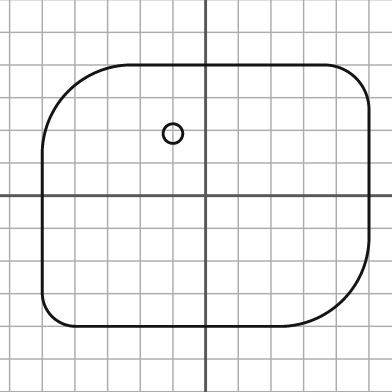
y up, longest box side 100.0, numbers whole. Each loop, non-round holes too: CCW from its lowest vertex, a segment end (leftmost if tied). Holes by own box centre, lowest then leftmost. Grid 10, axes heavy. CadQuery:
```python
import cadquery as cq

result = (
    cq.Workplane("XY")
    .moveTo(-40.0, -40.0)
    .lineTo(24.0, -40.0)
    .threePointArc((42.0, -32.0), (50.0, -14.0))
    .lineTo(50.0, 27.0)
    .threePointArc((46.0, 36.0), (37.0, 40.0))
    .lineTo(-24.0, 40.0)
    .threePointArc((-42.0, 32.0), (-50.0, 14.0))
    .lineTo(-50.0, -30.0)
    .threePointArc((-47.0, -37.0), (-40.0, -40.0))
    .close()
    .moveTo(-10.0, 19.0)
    .circle(3.0)
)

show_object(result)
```